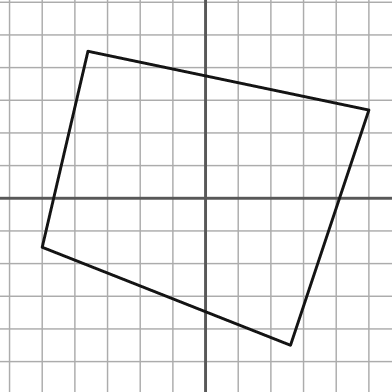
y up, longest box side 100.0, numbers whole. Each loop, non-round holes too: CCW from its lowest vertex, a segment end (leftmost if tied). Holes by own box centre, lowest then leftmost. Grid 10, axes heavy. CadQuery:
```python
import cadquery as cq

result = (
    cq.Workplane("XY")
    .moveTo(26.0, -45.0)
    .lineTo(50.0, 27.0)
    .lineTo(-36.0, 45.0)
    .lineTo(-50.0, -15.0)
    .close()
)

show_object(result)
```